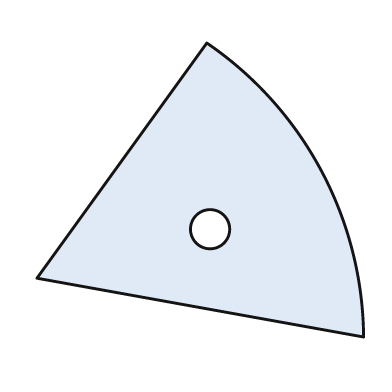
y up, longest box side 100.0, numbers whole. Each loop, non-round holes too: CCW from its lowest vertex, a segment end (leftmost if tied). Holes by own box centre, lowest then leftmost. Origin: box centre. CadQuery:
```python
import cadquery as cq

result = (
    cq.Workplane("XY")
    .moveTo(50.0, -45.0)
    .threePointArc((37.0, 6.0), (2.0, 45.0))
    .lineTo(-50.0, -27.0)
    .close()
    .moveTo(3.0, -12.0)
    .circle(6.0)
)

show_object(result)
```